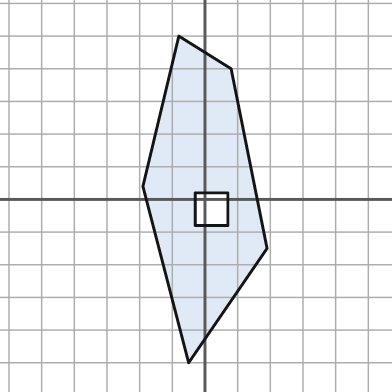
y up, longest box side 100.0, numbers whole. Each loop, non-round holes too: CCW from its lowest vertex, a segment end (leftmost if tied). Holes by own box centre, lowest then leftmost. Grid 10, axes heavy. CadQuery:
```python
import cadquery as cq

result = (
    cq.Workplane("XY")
    .moveTo(-5.0, -50.0)
    .lineTo(19.0, -15.0)
    .lineTo(8.0, 40.0)
    .lineTo(-8.0, 50.0)
    .lineTo(-19.0, 4.0)
    .close()
    .moveTo(-3.0, -8.0)
    .lineTo(7.0, -8.0)
    .lineTo(7.0, 2.0)
    .lineTo(-3.0, 2.0)
    .close()
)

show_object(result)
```